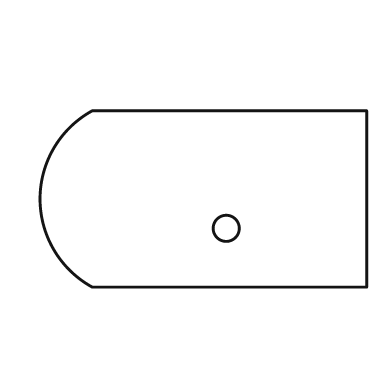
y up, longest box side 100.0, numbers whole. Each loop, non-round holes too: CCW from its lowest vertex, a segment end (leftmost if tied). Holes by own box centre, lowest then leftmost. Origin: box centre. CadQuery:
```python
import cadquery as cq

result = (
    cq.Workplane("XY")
    .moveTo(-34.0, -27.0)
    .lineTo(50.0, -27.0)
    .lineTo(50.0, 27.0)
    .lineTo(-34.0, 27.0)
    .threePointArc((-50.0, 0.0), (-34.0, -27.0))
    .close()
    .moveTo(7.0, -9.0)
    .circle(4.0)
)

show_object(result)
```